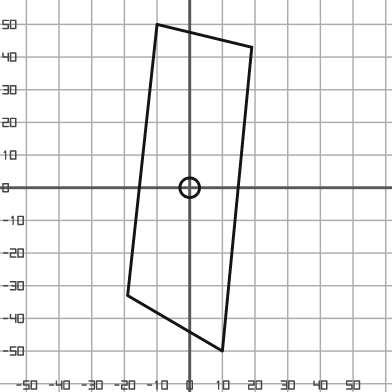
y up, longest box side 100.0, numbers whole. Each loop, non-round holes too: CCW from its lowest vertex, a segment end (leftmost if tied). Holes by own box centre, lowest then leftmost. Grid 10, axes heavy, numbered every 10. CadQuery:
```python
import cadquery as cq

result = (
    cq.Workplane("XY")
    .moveTo(10.0, -50.0)
    .lineTo(19.0, 43.0)
    .lineTo(-10.0, 50.0)
    .lineTo(-19.0, -33.0)
    .close()
    .moveTo(0.0, 0.0)
    .circle(3.0)
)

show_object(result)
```